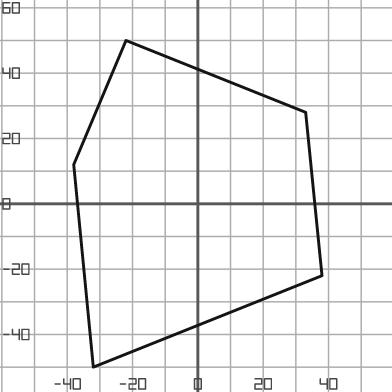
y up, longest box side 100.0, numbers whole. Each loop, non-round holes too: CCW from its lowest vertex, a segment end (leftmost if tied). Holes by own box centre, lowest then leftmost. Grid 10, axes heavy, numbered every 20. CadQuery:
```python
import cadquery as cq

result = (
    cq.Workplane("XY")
    .moveTo(-32.0, -50.0)
    .lineTo(38.0, -22.0)
    .lineTo(33.0, 28.0)
    .lineTo(-22.0, 50.0)
    .lineTo(-38.0, 12.0)
    .close()
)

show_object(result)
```